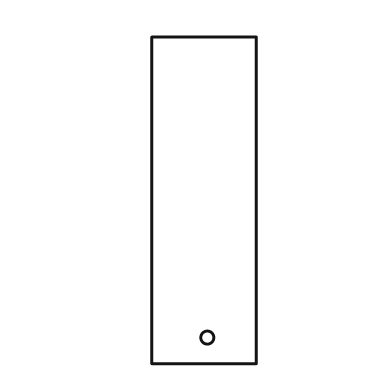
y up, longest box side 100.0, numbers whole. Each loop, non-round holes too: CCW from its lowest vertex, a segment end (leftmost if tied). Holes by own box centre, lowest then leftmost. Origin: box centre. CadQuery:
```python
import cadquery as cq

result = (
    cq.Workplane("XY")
    .moveTo(-16.0, -50.0)
    .lineTo(16.0, -50.0)
    .lineTo(16.0, 50.0)
    .lineTo(-16.0, 50.0)
    .close()
    .moveTo(1.0, -42.0)
    .circle(2.0)
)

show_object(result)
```